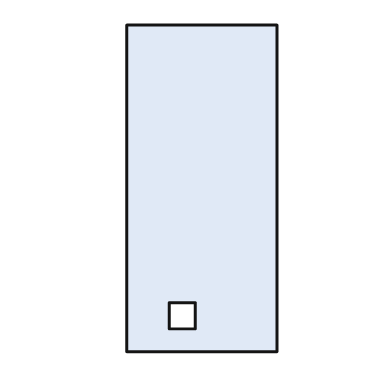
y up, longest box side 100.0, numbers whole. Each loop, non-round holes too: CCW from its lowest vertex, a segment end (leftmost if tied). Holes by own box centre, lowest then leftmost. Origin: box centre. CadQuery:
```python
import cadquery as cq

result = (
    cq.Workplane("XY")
    .moveTo(-23.0, -50.0)
    .lineTo(23.0, -50.0)
    .lineTo(23.0, 50.0)
    .lineTo(-23.0, 50.0)
    .close()
    .moveTo(-10.0, -43.0)
    .lineTo(-2.0, -43.0)
    .lineTo(-2.0, -35.0)
    .lineTo(-10.0, -35.0)
    .close()
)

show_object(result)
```